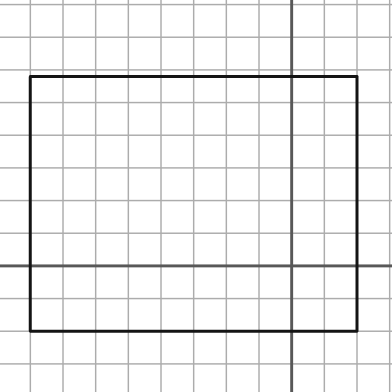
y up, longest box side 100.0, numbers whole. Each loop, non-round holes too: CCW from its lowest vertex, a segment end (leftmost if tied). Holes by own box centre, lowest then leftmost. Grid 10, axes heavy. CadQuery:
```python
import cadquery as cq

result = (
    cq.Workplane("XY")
    .moveTo(-80.0, -20.0)
    .lineTo(20.0, -20.0)
    .lineTo(20.0, 58.0)
    .lineTo(-80.0, 58.0)
    .close()
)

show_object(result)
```